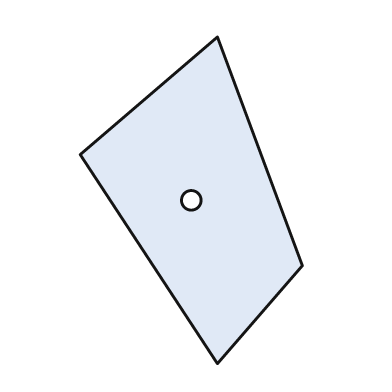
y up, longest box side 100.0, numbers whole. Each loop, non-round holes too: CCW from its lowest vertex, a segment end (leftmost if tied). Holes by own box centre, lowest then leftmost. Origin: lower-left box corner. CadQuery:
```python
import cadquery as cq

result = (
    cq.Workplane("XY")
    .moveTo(42.0, 0.0)
    .lineTo(68.0, 30.0)
    .lineTo(42.0, 100.0)
    .lineTo(0.0, 64.0)
    .close()
    .moveTo(34.0, 50.0)
    .circle(3.0)
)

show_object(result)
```